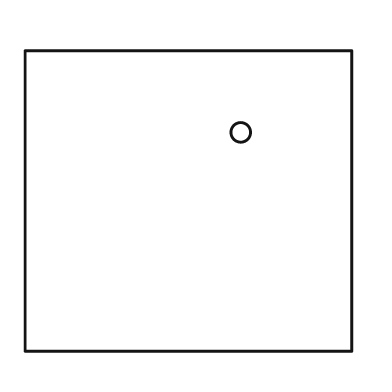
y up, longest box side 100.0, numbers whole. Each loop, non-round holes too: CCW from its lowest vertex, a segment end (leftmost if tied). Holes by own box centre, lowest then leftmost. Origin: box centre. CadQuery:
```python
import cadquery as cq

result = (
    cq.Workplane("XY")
    .moveTo(-50.0, -46.0)
    .lineTo(50.0, -46.0)
    .lineTo(50.0, 46.0)
    .lineTo(-50.0, 46.0)
    .close()
    .moveTo(16.0, 21.0)
    .circle(3.0)
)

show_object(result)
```